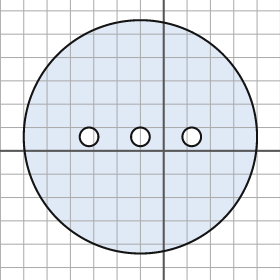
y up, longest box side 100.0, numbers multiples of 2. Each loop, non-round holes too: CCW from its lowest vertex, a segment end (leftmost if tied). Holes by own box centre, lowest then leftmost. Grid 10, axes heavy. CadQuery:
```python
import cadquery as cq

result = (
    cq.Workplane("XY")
    .moveTo(-10.0, 6.0)
    .circle(50.0)
    .moveTo(-32.0, 6.0)
    .circle(4.0)
    .moveTo(-10.0, 6.0)
    .circle(4.0)
    .moveTo(12.0, 6.0)
    .circle(4.0)
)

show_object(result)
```